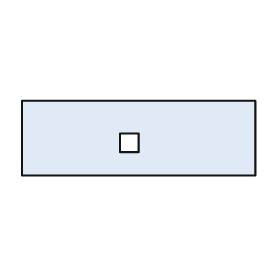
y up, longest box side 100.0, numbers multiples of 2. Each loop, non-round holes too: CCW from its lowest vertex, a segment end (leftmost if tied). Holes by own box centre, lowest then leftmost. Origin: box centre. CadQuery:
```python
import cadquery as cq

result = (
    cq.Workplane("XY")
    .moveTo(-50.0, -16.0)
    .lineTo(50.0, -16.0)
    .lineTo(50.0, 16.0)
    .lineTo(-50.0, 16.0)
    .close()
    .moveTo(-8.0, -6.0)
    .lineTo(0.0, -6.0)
    .lineTo(0.0, 2.0)
    .lineTo(-8.0, 2.0)
    .close()
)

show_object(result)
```